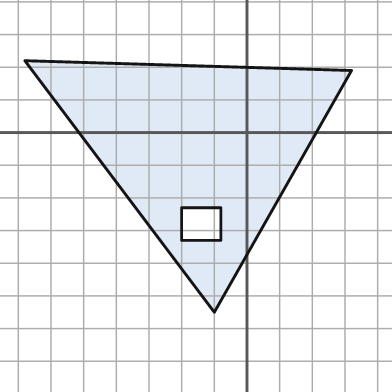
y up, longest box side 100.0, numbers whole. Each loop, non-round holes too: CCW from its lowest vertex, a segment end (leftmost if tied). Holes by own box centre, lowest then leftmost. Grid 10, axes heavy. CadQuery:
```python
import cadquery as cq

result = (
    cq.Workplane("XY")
    .moveTo(-10.0, -55.0)
    .lineTo(32.0, 19.0)
    .lineTo(-68.0, 22.0)
    .close()
    .moveTo(-20.0, -33.0)
    .lineTo(-8.0, -33.0)
    .lineTo(-8.0, -23.0)
    .lineTo(-20.0, -23.0)
    .close()
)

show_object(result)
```